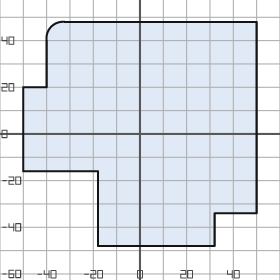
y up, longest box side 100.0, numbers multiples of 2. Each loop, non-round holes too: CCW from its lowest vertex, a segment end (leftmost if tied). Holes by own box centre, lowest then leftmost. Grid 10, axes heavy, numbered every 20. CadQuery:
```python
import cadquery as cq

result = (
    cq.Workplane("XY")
    .moveTo(-18.0, -48.0)
    .lineTo(32.0, -48.0)
    .lineTo(32.0, -34.0)
    .lineTo(50.0, -34.0)
    .lineTo(50.0, 48.0)
    .lineTo(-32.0, 48.0)
    .threePointArc((-38.0, 46.0), (-40.0, 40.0))
    .lineTo(-40.0, 20.0)
    .lineTo(-50.0, 20.0)
    .lineTo(-50.0, -16.0)
    .lineTo(-18.0, -16.0)
    .close()
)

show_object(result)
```